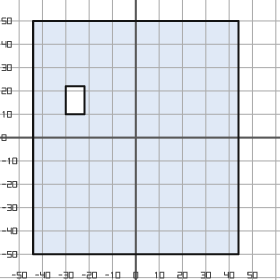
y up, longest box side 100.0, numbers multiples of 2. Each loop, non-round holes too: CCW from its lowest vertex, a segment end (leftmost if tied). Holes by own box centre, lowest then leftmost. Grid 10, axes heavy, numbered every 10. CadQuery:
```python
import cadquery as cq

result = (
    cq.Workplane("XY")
    .moveTo(-44.0, -50.0)
    .lineTo(44.0, -50.0)
    .lineTo(44.0, 50.0)
    .lineTo(-44.0, 50.0)
    .close()
    .moveTo(-30.0, 10.0)
    .lineTo(-22.0, 10.0)
    .lineTo(-22.0, 22.0)
    .lineTo(-30.0, 22.0)
    .close()
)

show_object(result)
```